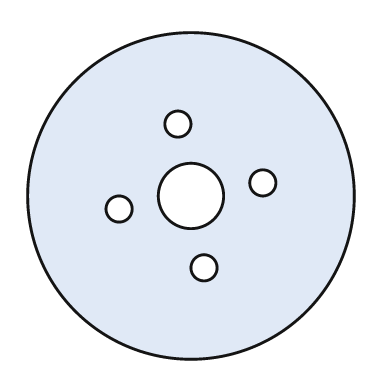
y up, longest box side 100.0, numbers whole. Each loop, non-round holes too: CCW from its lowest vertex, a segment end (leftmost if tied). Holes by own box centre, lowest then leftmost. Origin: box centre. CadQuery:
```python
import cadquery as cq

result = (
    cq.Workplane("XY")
    .moveTo(0.0, 0.0)
    .circle(50.0)
    .moveTo(4.0, -22.0)
    .circle(4.0)
    .moveTo(-22.0, -4.0)
    .circle(4.0)
    .moveTo(0.0, 0.0)
    .circle(10.0)
    .moveTo(22.0, 4.0)
    .circle(4.0)
    .moveTo(-4.0, 22.0)
    .circle(4.0)
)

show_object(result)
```